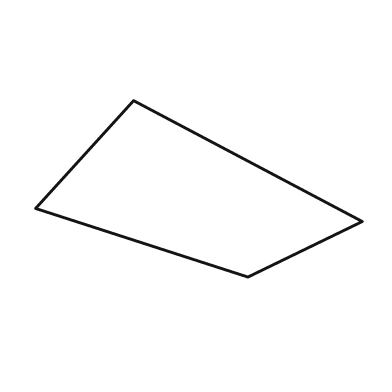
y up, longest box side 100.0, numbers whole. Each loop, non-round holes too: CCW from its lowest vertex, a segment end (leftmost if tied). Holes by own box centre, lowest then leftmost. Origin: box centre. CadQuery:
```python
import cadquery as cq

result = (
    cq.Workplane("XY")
    .moveTo(15.0, -27.0)
    .lineTo(50.0, -10.0)
    .lineTo(-20.0, 27.0)
    .lineTo(-50.0, -6.0)
    .close()
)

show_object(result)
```